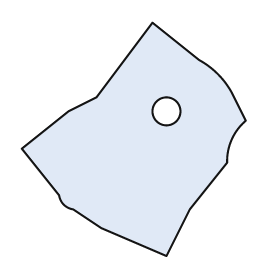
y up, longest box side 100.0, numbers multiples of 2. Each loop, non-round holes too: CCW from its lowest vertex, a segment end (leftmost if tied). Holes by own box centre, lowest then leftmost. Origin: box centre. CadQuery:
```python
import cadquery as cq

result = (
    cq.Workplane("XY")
    .moveTo(14.0, -50.0)
    .lineTo(24.0, -30.0)
    .lineTo(40.0, -10.0)
    .threePointArc((42.0, 0.0), (48.0, 8.0))
    .lineTo(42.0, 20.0)
    .threePointArc((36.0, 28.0), (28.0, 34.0))
    .lineTo(8.0, 50.0)
    .lineTo(-16.0, 18.0)
    .lineTo(-28.0, 12.0)
    .lineTo(-48.0, -4.0)
    .lineTo(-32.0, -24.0)
    .threePointArc((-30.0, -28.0), (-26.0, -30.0))
    .lineTo(-14.0, -38.0)
    .close()
    .moveTo(14.0, 12.0)
    .circle(6.0)
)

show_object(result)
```